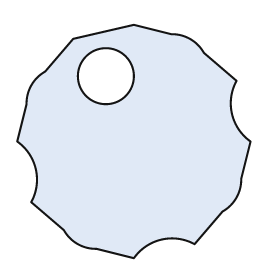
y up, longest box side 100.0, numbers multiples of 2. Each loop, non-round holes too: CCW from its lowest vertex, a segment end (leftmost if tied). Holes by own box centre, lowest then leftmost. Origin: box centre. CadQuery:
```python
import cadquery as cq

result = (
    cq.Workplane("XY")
    .moveTo(0.0, -50.0)
    .threePointArc((12.0, -42.0), (26.0, -44.0))
    .lineTo(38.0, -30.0)
    .threePointArc((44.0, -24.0), (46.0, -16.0))
    .lineTo(50.0, 0.0)
    .threePointArc((42.0, 12.0), (44.0, 26.0))
    .lineTo(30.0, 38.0)
    .threePointArc((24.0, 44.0), (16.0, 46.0))
    .lineTo(0.0, 50.0)
    .lineTo(-26.0, 44.0)
    .lineTo(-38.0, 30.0)
    .threePointArc((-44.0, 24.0), (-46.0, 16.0))
    .lineTo(-50.0, 0.0)
    .threePointArc((-42.0, -12.0), (-44.0, -26.0))
    .lineTo(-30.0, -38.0)
    .threePointArc((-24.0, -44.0), (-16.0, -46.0))
    .close()
    .moveTo(-12.0, 28.0)
    .circle(12.0)
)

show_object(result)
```